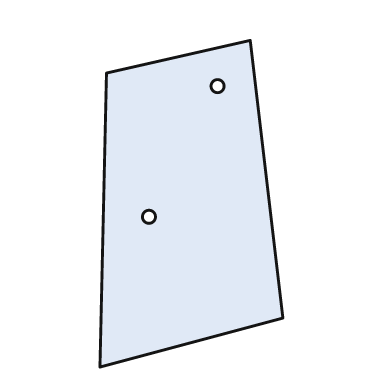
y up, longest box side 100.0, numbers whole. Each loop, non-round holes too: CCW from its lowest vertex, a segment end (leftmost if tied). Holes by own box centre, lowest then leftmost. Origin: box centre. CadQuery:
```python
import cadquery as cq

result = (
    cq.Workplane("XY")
    .moveTo(-28.0, -50.0)
    .lineTo(28.0, -35.0)
    .lineTo(18.0, 50.0)
    .lineTo(-26.0, 40.0)
    .close()
    .moveTo(-13.0, -4.0)
    .circle(2.0)
    .moveTo(8.0, 36.0)
    .circle(2.0)
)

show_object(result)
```